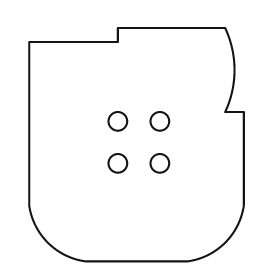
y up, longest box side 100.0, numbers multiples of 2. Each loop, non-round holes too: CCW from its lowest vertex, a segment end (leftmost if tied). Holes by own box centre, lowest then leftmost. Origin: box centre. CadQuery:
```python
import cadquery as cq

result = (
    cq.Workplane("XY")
    .moveTo(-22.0, -50.0)
    .lineTo(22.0, -50.0)
    .threePointArc((38.0, -42.0), (46.0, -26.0))
    .lineTo(46.0, 14.0)
    .lineTo(38.0, 14.0)
    .threePointArc((42.0, 32.0), (38.0, 50.0))
    .lineTo(-8.0, 50.0)
    .lineTo(-8.0, 44.0)
    .lineTo(-46.0, 44.0)
    .lineTo(-46.0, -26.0)
    .threePointArc((-38.0, -42.0), (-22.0, -50.0))
    .close()
    .moveTo(-8.0, -8.0)
    .circle(4.0)
    .moveTo(10.0, -8.0)
    .circle(4.0)
    .moveTo(-8.0, 10.0)
    .circle(4.0)
    .moveTo(10.0, 10.0)
    .circle(4.0)
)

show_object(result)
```